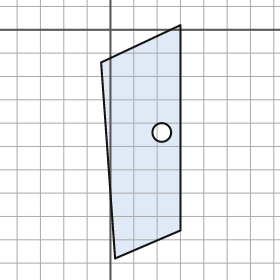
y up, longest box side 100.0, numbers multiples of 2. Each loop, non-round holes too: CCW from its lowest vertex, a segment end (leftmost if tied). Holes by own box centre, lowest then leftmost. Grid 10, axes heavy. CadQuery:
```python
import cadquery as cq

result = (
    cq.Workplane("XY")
    .moveTo(2.0, -98.0)
    .lineTo(30.0, -86.0)
    .lineTo(30.0, 2.0)
    .lineTo(-4.0, -14.0)
    .close()
    .moveTo(22.0, -44.0)
    .circle(4.0)
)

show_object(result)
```